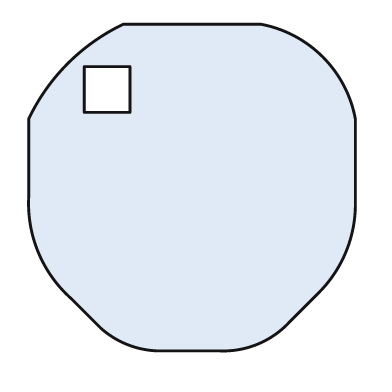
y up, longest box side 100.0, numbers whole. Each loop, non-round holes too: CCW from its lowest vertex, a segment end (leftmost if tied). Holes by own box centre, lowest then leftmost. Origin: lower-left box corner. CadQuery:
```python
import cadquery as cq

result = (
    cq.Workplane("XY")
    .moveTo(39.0, 0.0)
    .lineTo(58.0, 0.0)
    .threePointArc((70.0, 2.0), (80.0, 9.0))
    .lineTo(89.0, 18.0)
    .threePointArc((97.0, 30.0), (100.0, 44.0))
    .lineTo(100.0, 71.0)
    .threePointArc((90.0, 90.0), (71.0, 100.0))
    .lineTo(29.0, 100.0)
    .threePointArc((12.0, 88.0), (0.0, 71.0))
    .lineTo(0.0, 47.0)
    .threePointArc((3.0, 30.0), (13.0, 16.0))
    .lineTo(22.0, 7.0)
    .threePointArc((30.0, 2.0), (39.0, 0.0))
    .close()
    .moveTo(17.0, 73.0)
    .lineTo(31.0, 73.0)
    .lineTo(31.0, 87.0)
    .lineTo(17.0, 87.0)
    .close()
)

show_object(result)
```